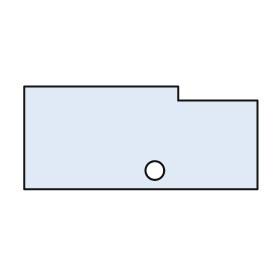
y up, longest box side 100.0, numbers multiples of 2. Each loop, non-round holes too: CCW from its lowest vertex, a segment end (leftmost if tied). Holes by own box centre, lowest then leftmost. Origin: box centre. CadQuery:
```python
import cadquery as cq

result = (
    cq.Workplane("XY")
    .moveTo(-50.0, -22.0)
    .lineTo(50.0, -22.0)
    .lineTo(50.0, 16.0)
    .lineTo(16.0, 16.0)
    .lineTo(16.0, 22.0)
    .lineTo(-50.0, 22.0)
    .close()
    .moveTo(6.0, -14.0)
    .circle(4.0)
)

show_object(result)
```